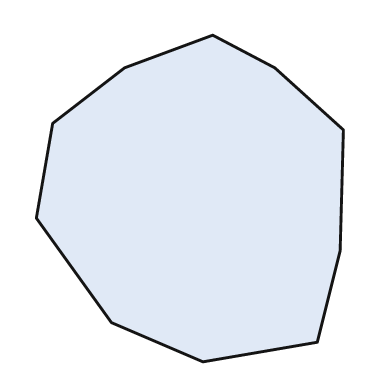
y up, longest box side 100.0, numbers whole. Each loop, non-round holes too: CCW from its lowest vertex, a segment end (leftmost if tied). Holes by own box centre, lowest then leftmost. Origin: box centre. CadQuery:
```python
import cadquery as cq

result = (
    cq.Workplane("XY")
    .moveTo(4.0, -50.0)
    .lineTo(39.0, -44.0)
    .lineTo(46.0, -16.0)
    .lineTo(47.0, 21.0)
    .lineTo(26.0, 40.0)
    .lineTo(7.0, 50.0)
    .lineTo(-20.0, 40.0)
    .lineTo(-42.0, 23.0)
    .lineTo(-47.0, -6.0)
    .lineTo(-24.0, -38.0)
    .close()
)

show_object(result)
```